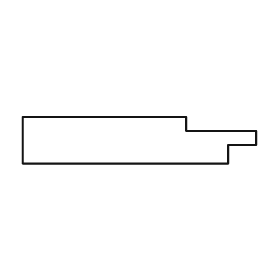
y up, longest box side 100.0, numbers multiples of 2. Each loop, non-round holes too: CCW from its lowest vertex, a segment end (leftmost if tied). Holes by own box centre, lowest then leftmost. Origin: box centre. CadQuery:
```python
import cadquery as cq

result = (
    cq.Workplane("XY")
    .moveTo(-50.0, -10.0)
    .lineTo(38.0, -10.0)
    .lineTo(38.0, -2.0)
    .lineTo(50.0, -2.0)
    .lineTo(50.0, 4.0)
    .lineTo(20.0, 4.0)
    .lineTo(20.0, 10.0)
    .lineTo(-50.0, 10.0)
    .close()
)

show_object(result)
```